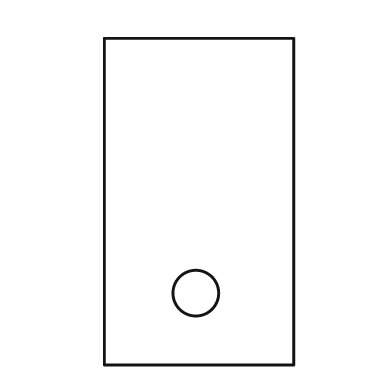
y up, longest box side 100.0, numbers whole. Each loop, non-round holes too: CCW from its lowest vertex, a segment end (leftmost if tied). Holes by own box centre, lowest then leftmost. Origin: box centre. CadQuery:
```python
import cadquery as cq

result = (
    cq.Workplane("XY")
    .moveTo(-29.0, -50.0)
    .lineTo(29.0, -50.0)
    .lineTo(29.0, 50.0)
    .lineTo(-29.0, 50.0)
    .close()
    .moveTo(-1.0, -28.0)
    .circle(7.0)
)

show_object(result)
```